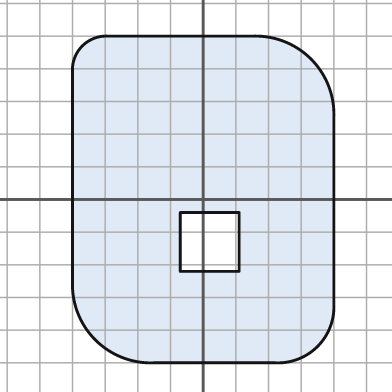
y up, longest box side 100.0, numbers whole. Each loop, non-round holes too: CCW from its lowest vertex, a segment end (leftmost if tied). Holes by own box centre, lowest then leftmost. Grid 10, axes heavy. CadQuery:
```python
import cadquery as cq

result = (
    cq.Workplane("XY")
    .moveTo(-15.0, -50.0)
    .lineTo(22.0, -50.0)
    .threePointArc((35.0, -45.0), (40.0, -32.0))
    .lineTo(40.0, 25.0)
    .threePointArc((33.0, 43.0), (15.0, 50.0))
    .lineTo(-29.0, 50.0)
    .threePointArc((-37.0, 47.0), (-40.0, 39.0))
    .lineTo(-40.0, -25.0)
    .threePointArc((-33.0, -43.0), (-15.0, -50.0))
    .close()
    .moveTo(-7.0, -22.0)
    .lineTo(11.0, -22.0)
    .lineTo(11.0, -4.0)
    .lineTo(-7.0, -4.0)
    .close()
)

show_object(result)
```